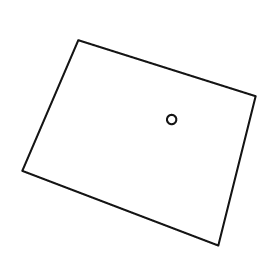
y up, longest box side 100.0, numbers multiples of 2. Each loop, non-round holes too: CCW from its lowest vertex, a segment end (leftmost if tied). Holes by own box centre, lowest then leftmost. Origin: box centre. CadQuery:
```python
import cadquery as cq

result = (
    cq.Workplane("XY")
    .moveTo(34.0, -44.0)
    .lineTo(50.0, 20.0)
    .lineTo(-26.0, 44.0)
    .lineTo(-50.0, -12.0)
    .close()
    .moveTo(14.0, 10.0)
    .circle(2.0)
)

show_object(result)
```